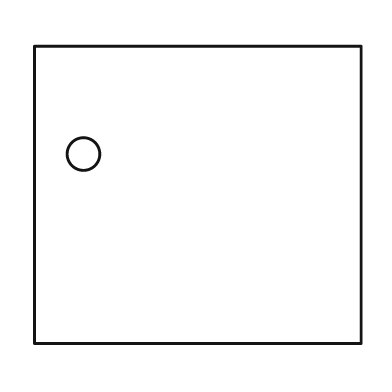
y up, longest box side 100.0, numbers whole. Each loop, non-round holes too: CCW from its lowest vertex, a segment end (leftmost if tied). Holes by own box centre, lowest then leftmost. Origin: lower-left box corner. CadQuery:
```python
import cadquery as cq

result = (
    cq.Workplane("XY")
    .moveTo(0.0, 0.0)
    .lineTo(100.0, 0.0)
    .lineTo(100.0, 91.0)
    .lineTo(0.0, 91.0)
    .close()
    .moveTo(15.0, 58.0)
    .circle(5.0)
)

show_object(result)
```